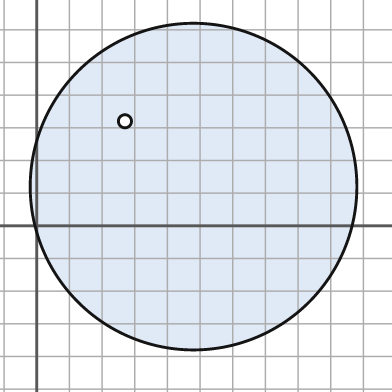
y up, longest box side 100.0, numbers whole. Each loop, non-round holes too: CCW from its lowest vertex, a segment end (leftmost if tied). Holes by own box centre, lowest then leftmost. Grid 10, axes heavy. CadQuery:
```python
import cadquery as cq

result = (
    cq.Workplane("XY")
    .moveTo(48.0, 12.0)
    .circle(50.0)
    .moveTo(27.0, 32.0)
    .circle(2.0)
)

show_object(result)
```